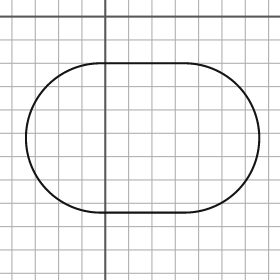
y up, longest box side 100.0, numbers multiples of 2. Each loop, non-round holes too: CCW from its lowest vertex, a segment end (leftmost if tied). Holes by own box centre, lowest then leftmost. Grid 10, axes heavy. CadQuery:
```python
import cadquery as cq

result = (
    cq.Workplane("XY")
    .moveTo(-2.0, -84.0)
    .lineTo(34.0, -84.0)
    .threePointArc((66.0, -52.0), (34.0, -20.0))
    .lineTo(-2.0, -20.0)
    .threePointArc((-34.0, -52.0), (-2.0, -84.0))
    .close()
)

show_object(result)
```